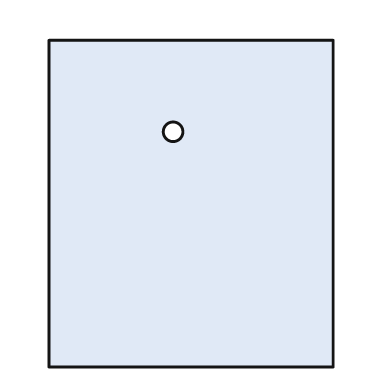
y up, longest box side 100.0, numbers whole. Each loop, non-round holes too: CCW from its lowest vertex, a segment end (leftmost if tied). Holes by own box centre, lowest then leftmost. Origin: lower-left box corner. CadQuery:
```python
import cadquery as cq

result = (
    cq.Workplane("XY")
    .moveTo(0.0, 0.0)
    .lineTo(87.0, 0.0)
    .lineTo(87.0, 100.0)
    .lineTo(0.0, 100.0)
    .close()
    .moveTo(38.0, 72.0)
    .circle(3.0)
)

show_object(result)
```